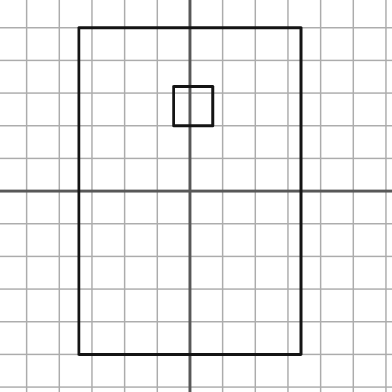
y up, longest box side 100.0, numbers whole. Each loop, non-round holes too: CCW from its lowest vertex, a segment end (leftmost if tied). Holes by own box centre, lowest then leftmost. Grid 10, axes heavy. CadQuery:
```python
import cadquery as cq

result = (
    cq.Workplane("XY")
    .moveTo(-34.0, -50.0)
    .lineTo(34.0, -50.0)
    .lineTo(34.0, 50.0)
    .lineTo(-34.0, 50.0)
    .close()
    .moveTo(-5.0, 20.0)
    .lineTo(7.0, 20.0)
    .lineTo(7.0, 32.0)
    .lineTo(-5.0, 32.0)
    .close()
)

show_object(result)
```